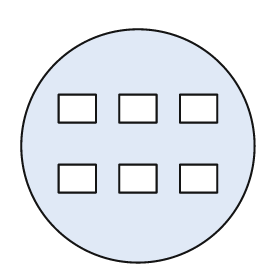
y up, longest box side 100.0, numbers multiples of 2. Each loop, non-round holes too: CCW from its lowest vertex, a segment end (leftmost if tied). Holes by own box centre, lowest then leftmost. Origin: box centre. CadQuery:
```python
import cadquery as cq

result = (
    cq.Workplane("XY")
    .moveTo(0.0, 0.0)
    .circle(50.0)
    .moveTo(-34.0, -20.0)
    .lineTo(-18.0, -20.0)
    .lineTo(-18.0, -8.0)
    .lineTo(-34.0, -8.0)
    .close()
    .moveTo(-8.0, -20.0)
    .lineTo(8.0, -20.0)
    .lineTo(8.0, -8.0)
    .lineTo(-8.0, -8.0)
    .close()
    .moveTo(18.0, -20.0)
    .lineTo(34.0, -20.0)
    .lineTo(34.0, -8.0)
    .lineTo(18.0, -8.0)
    .close()
    .moveTo(-34.0, 10.0)
    .lineTo(-18.0, 10.0)
    .lineTo(-18.0, 22.0)
    .lineTo(-34.0, 22.0)
    .close()
    .moveTo(-8.0, 10.0)
    .lineTo(8.0, 10.0)
    .lineTo(8.0, 22.0)
    .lineTo(-8.0, 22.0)
    .close()
    .moveTo(18.0, 10.0)
    .lineTo(34.0, 10.0)
    .lineTo(34.0, 22.0)
    .lineTo(18.0, 22.0)
    .close()
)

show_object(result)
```